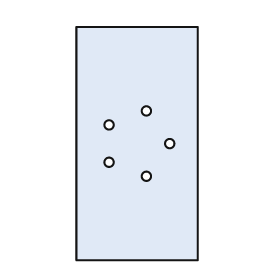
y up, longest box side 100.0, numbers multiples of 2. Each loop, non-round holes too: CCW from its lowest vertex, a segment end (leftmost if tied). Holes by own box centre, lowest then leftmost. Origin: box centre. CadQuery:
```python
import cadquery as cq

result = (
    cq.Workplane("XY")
    .moveTo(-26.0, -50.0)
    .lineTo(26.0, -50.0)
    .lineTo(26.0, 50.0)
    .lineTo(-26.0, 50.0)
    .close()
    .moveTo(4.0, -14.0)
    .circle(2.0)
    .moveTo(-12.0, -8.0)
    .circle(2.0)
    .moveTo(14.0, 0.0)
    .circle(2.0)
    .moveTo(-12.0, 8.0)
    .circle(2.0)
    .moveTo(4.0, 14.0)
    .circle(2.0)
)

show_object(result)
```